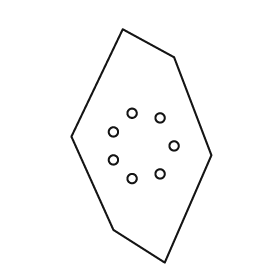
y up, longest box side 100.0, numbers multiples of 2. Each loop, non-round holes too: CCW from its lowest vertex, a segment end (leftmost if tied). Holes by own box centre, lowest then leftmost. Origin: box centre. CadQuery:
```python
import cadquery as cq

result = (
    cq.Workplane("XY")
    .moveTo(10.0, -50.0)
    .lineTo(30.0, -4.0)
    .lineTo(14.0, 38.0)
    .lineTo(-8.0, 50.0)
    .lineTo(-30.0, 4.0)
    .lineTo(-12.0, -36.0)
    .close()
    .moveTo(-4.0, -14.0)
    .circle(2.0)
    .moveTo(8.0, -12.0)
    .circle(2.0)
    .moveTo(-12.0, -6.0)
    .circle(2.0)
    .moveTo(14.0, 0.0)
    .circle(2.0)
    .moveTo(-12.0, 6.0)
    .circle(2.0)
    .moveTo(8.0, 12.0)
    .circle(2.0)
    .moveTo(-4.0, 14.0)
    .circle(2.0)
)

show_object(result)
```